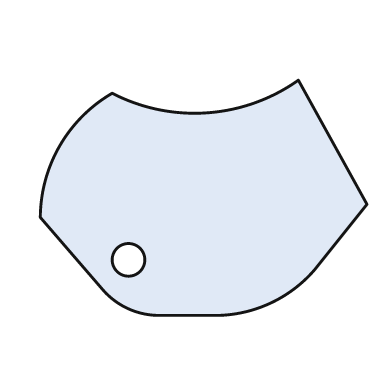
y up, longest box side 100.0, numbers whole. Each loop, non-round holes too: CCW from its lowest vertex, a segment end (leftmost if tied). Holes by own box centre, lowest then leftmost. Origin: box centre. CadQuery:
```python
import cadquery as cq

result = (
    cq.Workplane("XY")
    .moveTo(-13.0, -36.0)
    .lineTo(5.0, -36.0)
    .threePointArc((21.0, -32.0), (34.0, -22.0))
    .lineTo(50.0, -2.0)
    .lineTo(29.0, 36.0)
    .threePointArc((1.0, 26.0), (-28.0, 32.0))
    .threePointArc((-44.0, 16.0), (-50.0, -6.0))
    .lineTo(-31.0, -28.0)
    .threePointArc((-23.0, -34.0), (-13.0, -36.0))
    .close()
    .moveTo(-23.0, -19.0)
    .circle(5.0)
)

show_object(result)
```